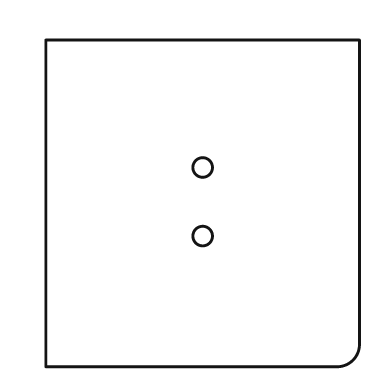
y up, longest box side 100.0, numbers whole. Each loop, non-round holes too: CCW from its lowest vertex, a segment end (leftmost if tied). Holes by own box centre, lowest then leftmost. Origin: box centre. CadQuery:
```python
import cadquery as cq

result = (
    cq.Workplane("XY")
    .moveTo(-48.0, -50.0)
    .lineTo(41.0, -50.0)
    .threePointArc((46.0, -48.0), (48.0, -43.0))
    .lineTo(48.0, 50.0)
    .lineTo(-48.0, 50.0)
    .close()
    .moveTo(0.0, -10.0)
    .circle(3.0)
    .moveTo(0.0, 11.0)
    .circle(3.0)
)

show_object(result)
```